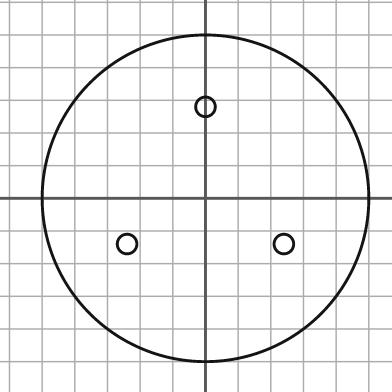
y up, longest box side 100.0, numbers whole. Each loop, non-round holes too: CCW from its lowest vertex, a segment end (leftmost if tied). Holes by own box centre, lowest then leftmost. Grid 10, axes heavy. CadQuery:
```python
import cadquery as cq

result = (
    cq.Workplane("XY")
    .moveTo(0.0, 0.0)
    .circle(50.0)
    .moveTo(-24.0, -14.0)
    .circle(3.0)
    .moveTo(24.0, -14.0)
    .circle(3.0)
    .moveTo(0.0, 28.0)
    .circle(3.0)
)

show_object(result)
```